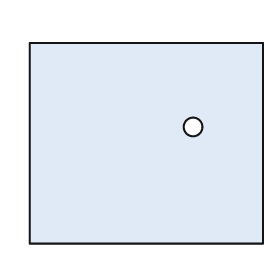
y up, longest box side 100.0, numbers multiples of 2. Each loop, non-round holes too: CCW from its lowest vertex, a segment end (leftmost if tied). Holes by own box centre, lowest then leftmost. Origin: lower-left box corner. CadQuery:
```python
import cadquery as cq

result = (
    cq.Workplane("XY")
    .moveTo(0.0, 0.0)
    .lineTo(100.0, 0.0)
    .lineTo(100.0, 86.0)
    .lineTo(0.0, 86.0)
    .close()
    .moveTo(70.0, 50.0)
    .circle(4.0)
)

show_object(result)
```